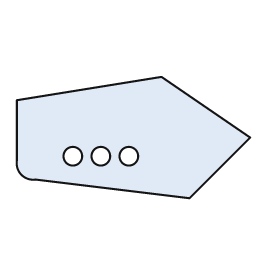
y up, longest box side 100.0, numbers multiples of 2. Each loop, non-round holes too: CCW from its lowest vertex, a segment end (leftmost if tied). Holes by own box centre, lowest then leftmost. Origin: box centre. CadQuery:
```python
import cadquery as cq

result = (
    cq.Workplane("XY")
    .moveTo(24.0, -26.0)
    .lineTo(50.0, 0.0)
    .lineTo(12.0, 26.0)
    .lineTo(-50.0, 16.0)
    .lineTo(-50.0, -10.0)
    .threePointArc((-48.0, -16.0), (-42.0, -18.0))
    .close()
    .moveTo(-26.0, -8.0)
    .circle(4.0)
    .moveTo(-14.0, -8.0)
    .circle(4.0)
    .moveTo(-2.0, -8.0)
    .circle(4.0)
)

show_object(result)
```